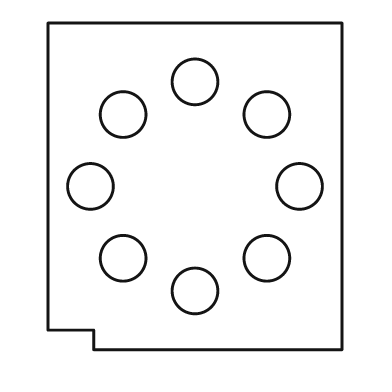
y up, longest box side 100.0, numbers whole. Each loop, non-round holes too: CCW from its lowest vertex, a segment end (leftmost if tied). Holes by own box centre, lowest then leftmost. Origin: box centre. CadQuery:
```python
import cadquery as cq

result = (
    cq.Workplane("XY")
    .moveTo(-31.0, -50.0)
    .lineTo(45.0, -50.0)
    .lineTo(45.0, 50.0)
    .lineTo(-45.0, 50.0)
    .lineTo(-45.0, -44.0)
    .lineTo(-31.0, -44.0)
    .close()
    .moveTo(0.0, -32.0)
    .circle(7.0)
    .moveTo(-22.0, -22.0)
    .circle(7.0)
    .moveTo(22.0, -22.0)
    .circle(7.0)
    .moveTo(-32.0, 0.0)
    .circle(7.0)
    .moveTo(32.0, 0.0)
    .circle(7.0)
    .moveTo(-22.0, 22.0)
    .circle(7.0)
    .moveTo(22.0, 22.0)
    .circle(7.0)
    .moveTo(0.0, 32.0)
    .circle(7.0)
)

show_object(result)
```